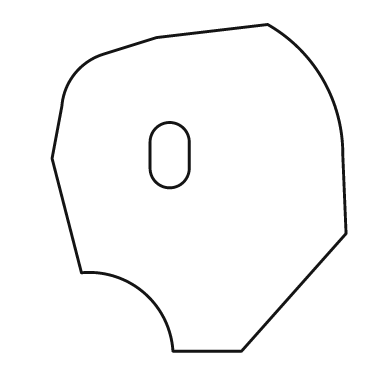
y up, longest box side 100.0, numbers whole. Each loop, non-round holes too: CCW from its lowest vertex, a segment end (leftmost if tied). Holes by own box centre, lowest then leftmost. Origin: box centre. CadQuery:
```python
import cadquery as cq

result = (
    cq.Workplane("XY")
    .moveTo(-8.0, -50.0)
    .lineTo(13.0, -50.0)
    .lineTo(45.0, -14.0)
    .lineTo(44.0, 10.0)
    .threePointArc((38.0, 33.0), (21.0, 50.0))
    .lineTo(-13.0, 46.0)
    .lineTo(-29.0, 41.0)
    .threePointArc((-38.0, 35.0), (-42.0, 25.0))
    .lineTo(-45.0, 9.0)
    .lineTo(-36.0, -26.0)
    .threePointArc((-17.0, -32.0), (-8.0, -50.0))
    .close()
    .moveTo(-15.0, 6.0)
    .threePointArc((-9.0, 0.0), (-3.0, 6.0))
    .lineTo(-3.0, 14.0)
    .threePointArc((-9.0, 20.0), (-15.0, 14.0))
    .close()
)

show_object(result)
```